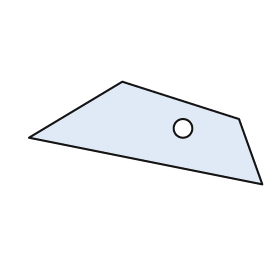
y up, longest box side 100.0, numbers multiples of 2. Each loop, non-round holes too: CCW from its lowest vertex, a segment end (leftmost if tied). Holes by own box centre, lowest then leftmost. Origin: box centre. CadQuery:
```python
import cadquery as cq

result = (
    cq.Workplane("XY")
    .moveTo(50.0, -22.0)
    .lineTo(40.0, 6.0)
    .lineTo(-10.0, 22.0)
    .lineTo(-50.0, -2.0)
    .close()
    .moveTo(16.0, 2.0)
    .circle(4.0)
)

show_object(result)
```